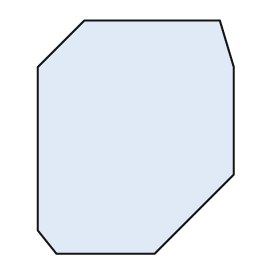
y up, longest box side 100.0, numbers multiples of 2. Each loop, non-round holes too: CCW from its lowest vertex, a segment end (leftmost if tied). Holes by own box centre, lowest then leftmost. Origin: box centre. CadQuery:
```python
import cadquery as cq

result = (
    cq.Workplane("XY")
    .moveTo(-34.0, -50.0)
    .lineTo(8.0, -50.0)
    .lineTo(42.0, -16.0)
    .lineTo(42.0, 30.0)
    .lineTo(36.0, 50.0)
    .lineTo(-22.0, 50.0)
    .lineTo(-42.0, 30.0)
    .lineTo(-42.0, -40.0)
    .close()
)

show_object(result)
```